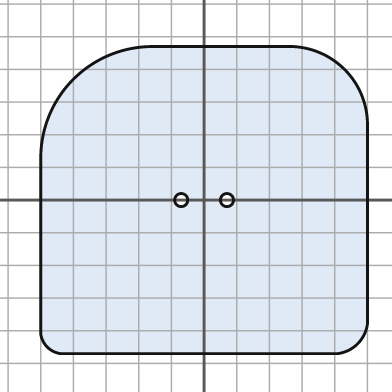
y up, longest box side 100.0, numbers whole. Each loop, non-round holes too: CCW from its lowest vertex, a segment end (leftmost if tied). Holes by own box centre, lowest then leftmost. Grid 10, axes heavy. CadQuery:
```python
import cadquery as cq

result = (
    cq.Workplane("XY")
    .moveTo(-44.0, -47.0)
    .lineTo(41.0, -47.0)
    .threePointArc((47.0, -44.0), (50.0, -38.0))
    .lineTo(50.0, 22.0)
    .threePointArc((43.0, 40.0), (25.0, 47.0))
    .lineTo(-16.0, 47.0)
    .threePointArc((-40.0, 37.0), (-50.0, 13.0))
    .lineTo(-50.0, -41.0)
    .threePointArc((-48.0, -45.0), (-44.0, -47.0))
    .close()
    .moveTo(-7.0, 0.0)
    .circle(2.0)
    .moveTo(7.0, 0.0)
    .circle(2.0)
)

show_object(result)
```